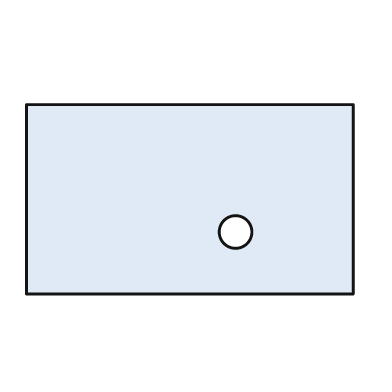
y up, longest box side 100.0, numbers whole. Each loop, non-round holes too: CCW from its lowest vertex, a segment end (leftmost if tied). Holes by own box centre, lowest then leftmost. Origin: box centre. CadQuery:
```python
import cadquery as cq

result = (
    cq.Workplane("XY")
    .moveTo(-50.0, -29.0)
    .lineTo(50.0, -29.0)
    .lineTo(50.0, 29.0)
    .lineTo(-50.0, 29.0)
    .close()
    .moveTo(14.0, -10.0)
    .circle(5.0)
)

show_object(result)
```